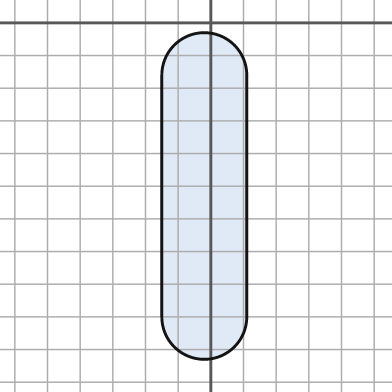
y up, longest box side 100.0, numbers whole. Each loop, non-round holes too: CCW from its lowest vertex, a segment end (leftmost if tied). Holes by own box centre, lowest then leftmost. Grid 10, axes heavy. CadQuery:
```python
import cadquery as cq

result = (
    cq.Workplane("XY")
    .moveTo(-15.0, -90.0)
    .threePointArc((-2.0, -103.0), (11.0, -90.0))
    .lineTo(11.0, -16.0)
    .threePointArc((-2.0, -3.0), (-15.0, -16.0))
    .close()
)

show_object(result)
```